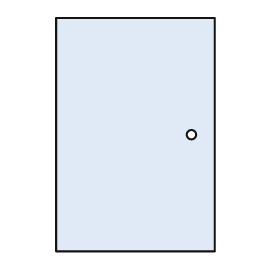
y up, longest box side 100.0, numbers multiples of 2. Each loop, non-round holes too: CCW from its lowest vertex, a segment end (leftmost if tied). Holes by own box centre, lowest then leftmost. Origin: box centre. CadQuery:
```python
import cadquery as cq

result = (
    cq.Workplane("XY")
    .moveTo(-34.0, -50.0)
    .lineTo(34.0, -50.0)
    .lineTo(34.0, 50.0)
    .lineTo(-34.0, 50.0)
    .close()
    .moveTo(24.0, 0.0)
    .circle(2.0)
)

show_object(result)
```